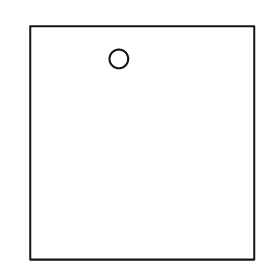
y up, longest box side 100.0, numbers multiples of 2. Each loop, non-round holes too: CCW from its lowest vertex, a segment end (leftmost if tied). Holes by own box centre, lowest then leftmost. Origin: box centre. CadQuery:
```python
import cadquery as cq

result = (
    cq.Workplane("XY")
    .moveTo(-48.0, -50.0)
    .lineTo(48.0, -50.0)
    .lineTo(48.0, 50.0)
    .lineTo(-48.0, 50.0)
    .close()
    .moveTo(-10.0, 36.0)
    .circle(4.0)
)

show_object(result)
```